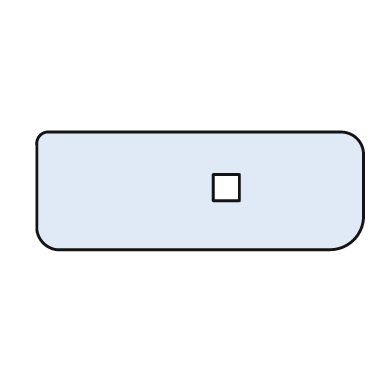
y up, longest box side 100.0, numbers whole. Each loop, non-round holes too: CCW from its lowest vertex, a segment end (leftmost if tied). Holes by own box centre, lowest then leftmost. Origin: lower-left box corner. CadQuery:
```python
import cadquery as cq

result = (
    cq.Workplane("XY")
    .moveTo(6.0, 0.0)
    .lineTo(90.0, 0.0)
    .threePointArc((97.0, 3.0), (100.0, 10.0))
    .lineTo(100.0, 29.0)
    .threePointArc((98.0, 34.0), (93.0, 36.0))
    .lineTo(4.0, 36.0)
    .threePointArc((1.0, 35.0), (0.0, 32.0))
    .lineTo(0.0, 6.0)
    .threePointArc((2.0, 2.0), (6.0, 0.0))
    .close()
    .moveTo(54.0, 15.0)
    .lineTo(62.0, 15.0)
    .lineTo(62.0, 23.0)
    .lineTo(54.0, 23.0)
    .close()
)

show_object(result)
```